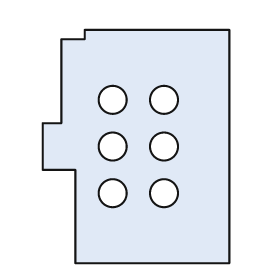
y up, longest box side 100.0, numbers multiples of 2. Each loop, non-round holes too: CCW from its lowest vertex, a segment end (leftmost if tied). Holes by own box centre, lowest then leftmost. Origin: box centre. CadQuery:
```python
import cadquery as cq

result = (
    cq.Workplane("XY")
    .moveTo(-26.0, -50.0)
    .lineTo(40.0, -50.0)
    .lineTo(40.0, 50.0)
    .lineTo(-22.0, 50.0)
    .lineTo(-22.0, 46.0)
    .lineTo(-32.0, 46.0)
    .lineTo(-32.0, 10.0)
    .lineTo(-40.0, 10.0)
    .lineTo(-40.0, -10.0)
    .lineTo(-26.0, -10.0)
    .close()
    .moveTo(-10.0, -20.0)
    .circle(6.0)
    .moveTo(12.0, -20.0)
    .circle(6.0)
    .moveTo(-10.0, 0.0)
    .circle(6.0)
    .moveTo(12.0, 0.0)
    .circle(6.0)
    .moveTo(-10.0, 20.0)
    .circle(6.0)
    .moveTo(12.0, 20.0)
    .circle(6.0)
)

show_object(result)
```